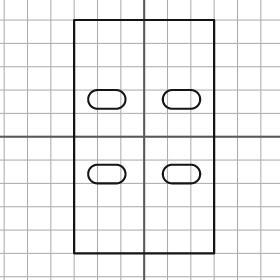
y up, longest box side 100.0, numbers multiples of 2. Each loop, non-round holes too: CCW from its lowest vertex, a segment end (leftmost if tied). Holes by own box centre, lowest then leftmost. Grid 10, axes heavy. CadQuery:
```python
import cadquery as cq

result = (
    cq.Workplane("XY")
    .moveTo(-30.0, -50.0)
    .lineTo(30.0, -50.0)
    .lineTo(30.0, 50.0)
    .lineTo(-30.0, 50.0)
    .close()
    .moveTo(-20.0, -20.0)
    .lineTo(-12.0, -20.0)
    .threePointArc((-8.0, -16.0), (-12.0, -12.0))
    .lineTo(-20.0, -12.0)
    .threePointArc((-24.0, -16.0), (-20.0, -20.0))
    .close()
    .moveTo(12.0, -20.0)
    .lineTo(20.0, -20.0)
    .threePointArc((24.0, -16.0), (20.0, -12.0))
    .lineTo(12.0, -12.0)
    .threePointArc((8.0, -16.0), (12.0, -20.0))
    .close()
    .moveTo(-20.0, 12.0)
    .lineTo(-12.0, 12.0)
    .threePointArc((-8.0, 16.0), (-12.0, 20.0))
    .lineTo(-20.0, 20.0)
    .threePointArc((-24.0, 16.0), (-20.0, 12.0))
    .close()
    .moveTo(12.0, 12.0)
    .lineTo(20.0, 12.0)
    .threePointArc((24.0, 16.0), (20.0, 20.0))
    .lineTo(12.0, 20.0)
    .threePointArc((8.0, 16.0), (12.0, 12.0))
    .close()
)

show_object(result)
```